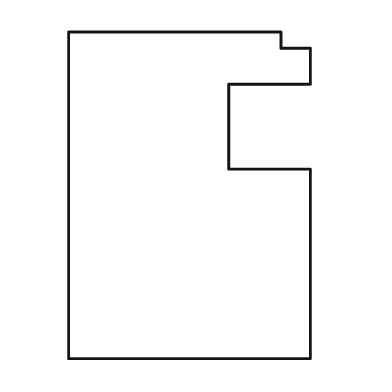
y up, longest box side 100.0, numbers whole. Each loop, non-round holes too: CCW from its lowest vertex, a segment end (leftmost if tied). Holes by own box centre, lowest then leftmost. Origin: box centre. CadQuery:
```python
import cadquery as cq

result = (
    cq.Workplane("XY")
    .moveTo(-37.0, -50.0)
    .lineTo(37.0, -50.0)
    .lineTo(37.0, 8.0)
    .lineTo(12.0, 8.0)
    .lineTo(12.0, 34.0)
    .lineTo(37.0, 34.0)
    .lineTo(37.0, 45.0)
    .lineTo(28.0, 45.0)
    .lineTo(28.0, 50.0)
    .lineTo(-37.0, 50.0)
    .close()
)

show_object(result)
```